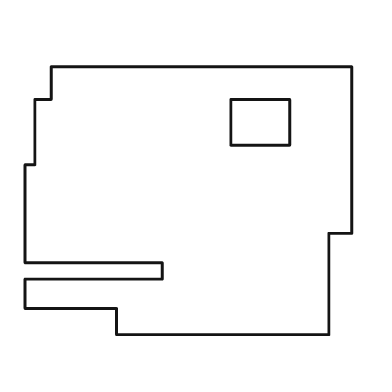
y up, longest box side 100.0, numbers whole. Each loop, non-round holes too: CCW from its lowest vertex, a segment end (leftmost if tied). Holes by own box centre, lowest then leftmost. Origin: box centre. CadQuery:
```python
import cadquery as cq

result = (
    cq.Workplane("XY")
    .moveTo(-22.0, -41.0)
    .lineTo(43.0, -41.0)
    .lineTo(43.0, -10.0)
    .lineTo(50.0, -10.0)
    .lineTo(50.0, 41.0)
    .lineTo(-42.0, 41.0)
    .lineTo(-42.0, 31.0)
    .lineTo(-47.0, 31.0)
    .lineTo(-47.0, 11.0)
    .lineTo(-50.0, 11.0)
    .lineTo(-50.0, -19.0)
    .lineTo(-8.0, -19.0)
    .lineTo(-8.0, -24.0)
    .lineTo(-50.0, -24.0)
    .lineTo(-50.0, -33.0)
    .lineTo(-22.0, -33.0)
    .close()
    .moveTo(13.0, 17.0)
    .lineTo(31.0, 17.0)
    .lineTo(31.0, 31.0)
    .lineTo(13.0, 31.0)
    .close()
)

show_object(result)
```